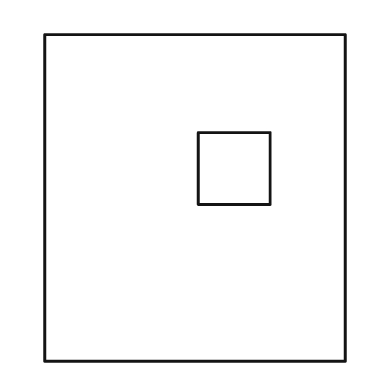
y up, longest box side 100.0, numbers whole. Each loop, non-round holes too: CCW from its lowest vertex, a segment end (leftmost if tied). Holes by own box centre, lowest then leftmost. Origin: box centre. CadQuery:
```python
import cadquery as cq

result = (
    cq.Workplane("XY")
    .moveTo(-46.0, -50.0)
    .lineTo(46.0, -50.0)
    .lineTo(46.0, 50.0)
    .lineTo(-46.0, 50.0)
    .close()
    .moveTo(1.0, -2.0)
    .lineTo(23.0, -2.0)
    .lineTo(23.0, 20.0)
    .lineTo(1.0, 20.0)
    .close()
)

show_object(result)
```